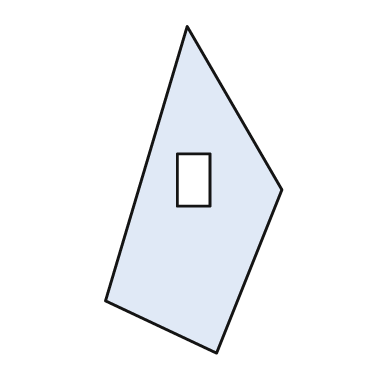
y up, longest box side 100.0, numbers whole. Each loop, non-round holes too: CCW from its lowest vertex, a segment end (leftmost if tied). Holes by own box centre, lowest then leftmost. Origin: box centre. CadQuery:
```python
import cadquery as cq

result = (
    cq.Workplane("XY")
    .moveTo(7.0, -50.0)
    .lineTo(27.0, 0.0)
    .lineTo(-2.0, 50.0)
    .lineTo(-27.0, -34.0)
    .close()
    .moveTo(-5.0, -5.0)
    .lineTo(5.0, -5.0)
    .lineTo(5.0, 11.0)
    .lineTo(-5.0, 11.0)
    .close()
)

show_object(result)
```